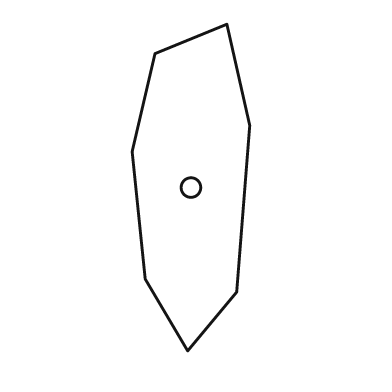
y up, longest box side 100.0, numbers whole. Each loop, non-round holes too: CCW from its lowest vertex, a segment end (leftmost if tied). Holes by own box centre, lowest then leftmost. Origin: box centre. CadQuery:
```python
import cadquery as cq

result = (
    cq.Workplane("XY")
    .moveTo(-1.0, -50.0)
    .lineTo(14.0, -32.0)
    .lineTo(18.0, 19.0)
    .lineTo(11.0, 50.0)
    .lineTo(-11.0, 41.0)
    .lineTo(-18.0, 11.0)
    .lineTo(-14.0, -28.0)
    .close()
    .moveTo(0.0, 0.0)
    .circle(3.0)
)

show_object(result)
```